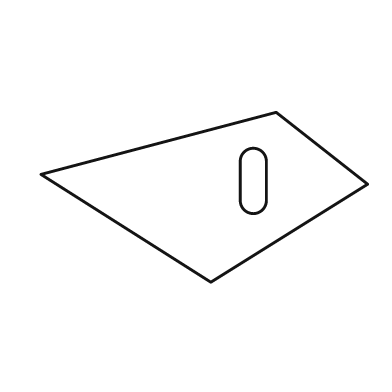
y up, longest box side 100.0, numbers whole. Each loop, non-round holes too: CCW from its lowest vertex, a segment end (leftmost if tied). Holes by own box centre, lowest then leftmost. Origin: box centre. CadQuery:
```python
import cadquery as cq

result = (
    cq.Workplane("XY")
    .moveTo(2.0, -26.0)
    .lineTo(50.0, 4.0)
    .lineTo(22.0, 26.0)
    .lineTo(-50.0, 7.0)
    .close()
    .moveTo(11.0, -1.0)
    .threePointArc((15.0, -5.0), (19.0, -1.0))
    .lineTo(19.0, 11.0)
    .threePointArc((15.0, 15.0), (11.0, 11.0))
    .close()
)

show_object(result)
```